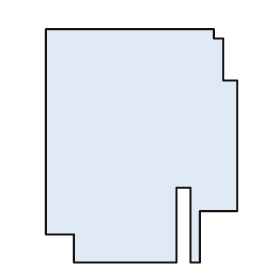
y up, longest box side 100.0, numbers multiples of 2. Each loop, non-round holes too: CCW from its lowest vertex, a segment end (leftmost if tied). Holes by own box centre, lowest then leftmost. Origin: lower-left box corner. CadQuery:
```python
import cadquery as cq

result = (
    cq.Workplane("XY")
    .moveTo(12.0, 0.0)
    .lineTo(56.0, 0.0)
    .lineTo(56.0, 32.0)
    .lineTo(62.0, 32.0)
    .lineTo(62.0, 0.0)
    .lineTo(66.0, 0.0)
    .lineTo(66.0, 22.0)
    .lineTo(82.0, 22.0)
    .lineTo(82.0, 78.0)
    .lineTo(76.0, 78.0)
    .lineTo(76.0, 96.0)
    .lineTo(72.0, 96.0)
    .lineTo(72.0, 100.0)
    .lineTo(0.0, 100.0)
    .lineTo(0.0, 12.0)
    .lineTo(12.0, 12.0)
    .close()
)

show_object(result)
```